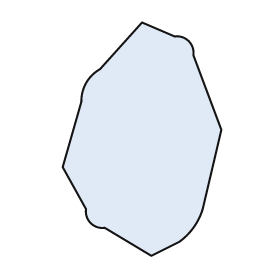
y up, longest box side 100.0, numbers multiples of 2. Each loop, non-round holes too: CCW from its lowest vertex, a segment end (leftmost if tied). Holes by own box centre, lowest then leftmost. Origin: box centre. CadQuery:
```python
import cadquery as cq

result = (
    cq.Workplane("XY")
    .moveTo(4.0, -50.0)
    .lineTo(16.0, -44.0)
    .threePointArc((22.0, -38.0), (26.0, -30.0))
    .lineTo(34.0, 4.0)
    .lineTo(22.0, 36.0)
    .threePointArc((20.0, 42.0), (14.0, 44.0))
    .lineTo(0.0, 50.0)
    .lineTo(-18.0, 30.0)
    .threePointArc((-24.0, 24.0), (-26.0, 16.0))
    .lineTo(-34.0, -12.0)
    .lineTo(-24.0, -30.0)
    .threePointArc((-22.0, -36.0), (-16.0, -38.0))
    .close()
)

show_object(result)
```